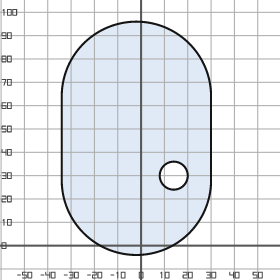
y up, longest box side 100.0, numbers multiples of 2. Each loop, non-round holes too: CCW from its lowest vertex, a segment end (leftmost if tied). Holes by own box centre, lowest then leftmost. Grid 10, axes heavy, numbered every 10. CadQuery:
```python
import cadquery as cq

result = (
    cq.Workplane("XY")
    .moveTo(-34.0, 28.0)
    .threePointArc((-2.0, -4.0), (30.0, 28.0))
    .lineTo(30.0, 64.0)
    .threePointArc((-2.0, 96.0), (-34.0, 64.0))
    .close()
    .moveTo(14.0, 30.0)
    .circle(6.0)
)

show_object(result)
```